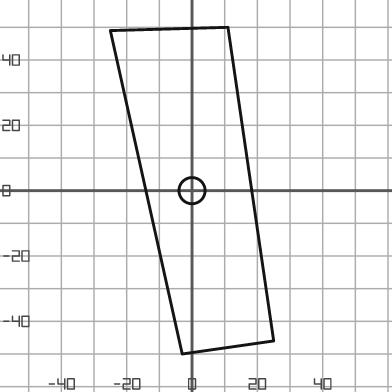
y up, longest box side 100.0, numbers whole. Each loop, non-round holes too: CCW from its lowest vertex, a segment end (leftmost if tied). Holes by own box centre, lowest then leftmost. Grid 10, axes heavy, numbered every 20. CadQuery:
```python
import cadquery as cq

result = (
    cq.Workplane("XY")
    .moveTo(-3.0, -50.0)
    .lineTo(25.0, -46.0)
    .lineTo(11.0, 50.0)
    .lineTo(-25.0, 49.0)
    .close()
    .moveTo(0.0, 0.0)
    .circle(4.0)
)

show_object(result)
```